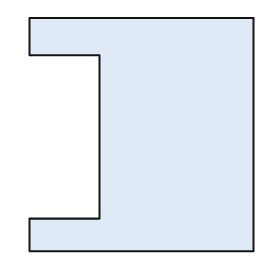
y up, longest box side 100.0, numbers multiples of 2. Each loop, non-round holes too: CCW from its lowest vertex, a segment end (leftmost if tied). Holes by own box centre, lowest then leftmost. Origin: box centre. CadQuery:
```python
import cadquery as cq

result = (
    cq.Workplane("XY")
    .moveTo(-48.0, -50.0)
    .lineTo(48.0, -50.0)
    .lineTo(48.0, 50.0)
    .lineTo(-48.0, 50.0)
    .lineTo(-48.0, 34.0)
    .lineTo(-18.0, 34.0)
    .lineTo(-18.0, -36.0)
    .lineTo(-48.0, -36.0)
    .close()
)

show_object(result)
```